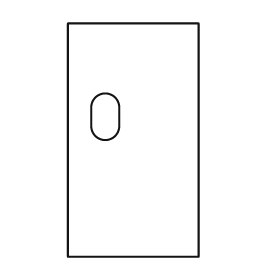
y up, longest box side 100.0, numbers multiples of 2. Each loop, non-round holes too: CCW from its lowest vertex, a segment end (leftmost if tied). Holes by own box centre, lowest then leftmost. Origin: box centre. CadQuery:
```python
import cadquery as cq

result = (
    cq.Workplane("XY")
    .moveTo(-28.0, -50.0)
    .lineTo(28.0, -50.0)
    .lineTo(28.0, 50.0)
    .lineTo(-28.0, 50.0)
    .close()
    .moveTo(-18.0, 6.0)
    .threePointArc((-12.0, 0.0), (-6.0, 6.0))
    .lineTo(-6.0, 14.0)
    .threePointArc((-12.0, 20.0), (-18.0, 14.0))
    .close()
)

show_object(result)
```